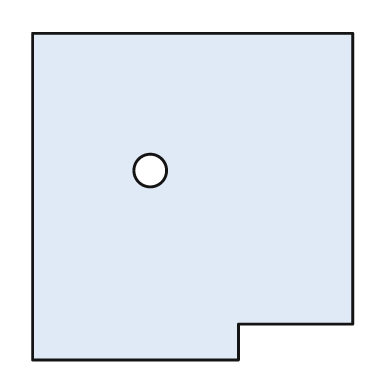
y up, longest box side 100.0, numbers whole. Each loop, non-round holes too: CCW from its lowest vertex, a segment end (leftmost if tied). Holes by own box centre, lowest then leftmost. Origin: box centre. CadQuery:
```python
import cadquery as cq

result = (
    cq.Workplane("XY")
    .moveTo(-49.0, -50.0)
    .lineTo(14.0, -50.0)
    .lineTo(14.0, -39.0)
    .lineTo(49.0, -39.0)
    .lineTo(49.0, 50.0)
    .lineTo(-49.0, 50.0)
    .close()
    .moveTo(-13.0, 8.0)
    .circle(5.0)
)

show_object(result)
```